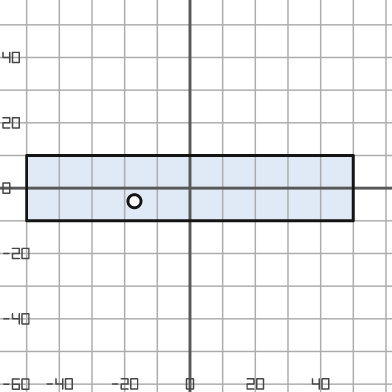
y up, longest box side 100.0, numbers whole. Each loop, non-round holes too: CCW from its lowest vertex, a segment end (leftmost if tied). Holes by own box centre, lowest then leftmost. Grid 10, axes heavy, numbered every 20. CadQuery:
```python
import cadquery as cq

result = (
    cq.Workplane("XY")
    .moveTo(-50.0, -10.0)
    .lineTo(50.0, -10.0)
    .lineTo(50.0, 10.0)
    .lineTo(-50.0, 10.0)
    .close()
    .moveTo(-17.0, -4.0)
    .circle(2.0)
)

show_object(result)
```